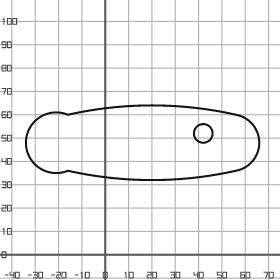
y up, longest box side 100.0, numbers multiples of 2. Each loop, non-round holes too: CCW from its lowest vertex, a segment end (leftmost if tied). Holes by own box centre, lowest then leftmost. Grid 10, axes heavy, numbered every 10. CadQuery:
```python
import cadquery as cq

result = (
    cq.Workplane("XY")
    .moveTo(-16.0, 36.0)
    .threePointArc((20.0, 32.0), (56.0, 36.0))
    .threePointArc((66.0, 48.0), (56.0, 60.0))
    .threePointArc((20.0, 64.0), (-16.0, 60.0))
    .threePointArc((-34.0, 48.0), (-16.0, 36.0))
    .close()
    .moveTo(42.0, 52.0)
    .circle(4.0)
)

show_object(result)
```